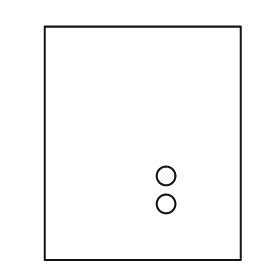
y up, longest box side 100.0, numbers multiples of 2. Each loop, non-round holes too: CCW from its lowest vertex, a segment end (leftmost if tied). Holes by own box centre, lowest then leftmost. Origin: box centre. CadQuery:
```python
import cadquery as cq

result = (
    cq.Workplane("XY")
    .moveTo(-42.0, -50.0)
    .lineTo(42.0, -50.0)
    .lineTo(42.0, 50.0)
    .lineTo(-42.0, 50.0)
    .close()
    .moveTo(10.0, -26.0)
    .circle(4.0)
    .moveTo(10.0, -14.0)
    .circle(4.0)
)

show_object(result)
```